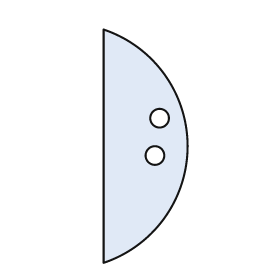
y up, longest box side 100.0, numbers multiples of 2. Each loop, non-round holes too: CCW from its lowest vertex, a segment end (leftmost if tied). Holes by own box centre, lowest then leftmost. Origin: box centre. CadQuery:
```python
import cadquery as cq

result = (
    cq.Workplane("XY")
    .moveTo(-18.0, -50.0)
    .threePointArc((18.0, 0.0), (-18.0, 50.0))
    .close()
    .moveTo(4.0, -4.0)
    .circle(4.0)
    .moveTo(6.0, 12.0)
    .circle(4.0)
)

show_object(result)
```